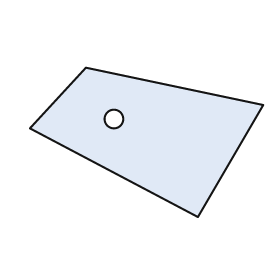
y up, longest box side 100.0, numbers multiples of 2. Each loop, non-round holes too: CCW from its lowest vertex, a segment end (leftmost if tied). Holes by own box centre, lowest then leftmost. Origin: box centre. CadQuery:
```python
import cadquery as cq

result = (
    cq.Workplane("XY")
    .moveTo(22.0, -32.0)
    .lineTo(50.0, 16.0)
    .lineTo(-26.0, 32.0)
    .lineTo(-50.0, 6.0)
    .close()
    .moveTo(-14.0, 10.0)
    .circle(4.0)
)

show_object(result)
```